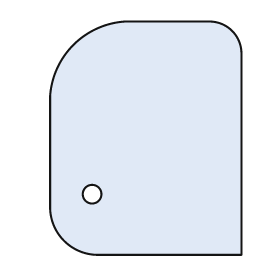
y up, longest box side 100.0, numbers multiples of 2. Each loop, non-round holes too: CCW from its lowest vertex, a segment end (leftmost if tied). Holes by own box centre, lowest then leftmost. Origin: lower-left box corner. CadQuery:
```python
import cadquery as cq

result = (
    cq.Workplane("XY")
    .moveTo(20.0, 0.0)
    .lineTo(82.0, 0.0)
    .lineTo(82.0, 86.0)
    .threePointArc((78.0, 96.0), (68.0, 100.0))
    .lineTo(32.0, 100.0)
    .threePointArc((10.0, 90.0), (0.0, 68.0))
    .lineTo(0.0, 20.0)
    .threePointArc((6.0, 6.0), (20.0, 0.0))
    .close()
    .moveTo(18.0, 26.0)
    .circle(4.0)
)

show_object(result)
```